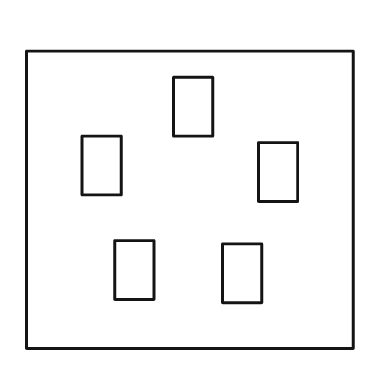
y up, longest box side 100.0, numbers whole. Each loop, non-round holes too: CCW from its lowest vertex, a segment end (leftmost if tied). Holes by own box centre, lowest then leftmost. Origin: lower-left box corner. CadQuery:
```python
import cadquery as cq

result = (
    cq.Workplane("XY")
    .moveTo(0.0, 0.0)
    .lineTo(100.0, 0.0)
    .lineTo(100.0, 91.0)
    .lineTo(0.0, 91.0)
    .close()
    .moveTo(60.0, 14.0)
    .lineTo(72.0, 14.0)
    .lineTo(72.0, 32.0)
    .lineTo(60.0, 32.0)
    .close()
    .moveTo(27.0, 15.0)
    .lineTo(39.0, 15.0)
    .lineTo(39.0, 33.0)
    .lineTo(27.0, 33.0)
    .close()
    .moveTo(71.0, 45.0)
    .lineTo(83.0, 45.0)
    .lineTo(83.0, 63.0)
    .lineTo(71.0, 63.0)
    .close()
    .moveTo(17.0, 47.0)
    .lineTo(29.0, 47.0)
    .lineTo(29.0, 65.0)
    .lineTo(17.0, 65.0)
    .close()
    .moveTo(45.0, 65.0)
    .lineTo(57.0, 65.0)
    .lineTo(57.0, 83.0)
    .lineTo(45.0, 83.0)
    .close()
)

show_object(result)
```